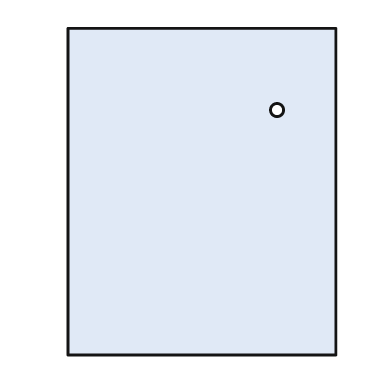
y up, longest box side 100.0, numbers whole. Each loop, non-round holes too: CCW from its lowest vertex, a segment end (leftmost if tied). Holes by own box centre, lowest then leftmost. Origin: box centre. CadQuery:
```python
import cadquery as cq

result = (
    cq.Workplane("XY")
    .moveTo(-41.0, -50.0)
    .lineTo(41.0, -50.0)
    .lineTo(41.0, 50.0)
    .lineTo(-41.0, 50.0)
    .close()
    .moveTo(23.0, 25.0)
    .circle(2.0)
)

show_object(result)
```